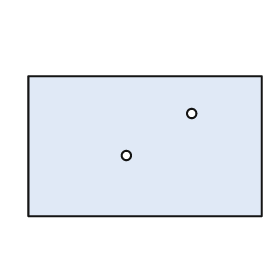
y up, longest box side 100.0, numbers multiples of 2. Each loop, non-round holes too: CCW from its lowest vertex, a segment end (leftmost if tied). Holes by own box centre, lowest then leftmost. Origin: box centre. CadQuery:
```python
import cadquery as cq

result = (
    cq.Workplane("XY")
    .moveTo(-50.0, -30.0)
    .lineTo(50.0, -30.0)
    .lineTo(50.0, 30.0)
    .lineTo(-50.0, 30.0)
    .close()
    .moveTo(-8.0, -4.0)
    .circle(2.0)
    .moveTo(20.0, 14.0)
    .circle(2.0)
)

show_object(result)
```